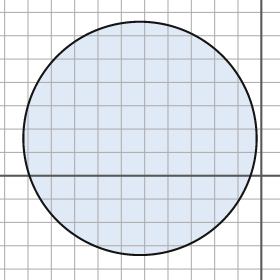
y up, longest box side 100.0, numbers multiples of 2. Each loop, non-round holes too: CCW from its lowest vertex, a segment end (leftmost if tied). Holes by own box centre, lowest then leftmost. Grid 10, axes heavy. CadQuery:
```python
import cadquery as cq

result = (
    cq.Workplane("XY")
    .moveTo(-52.0, 16.0)
    .circle(50.0)
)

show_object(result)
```